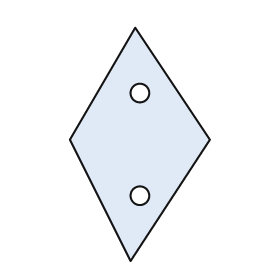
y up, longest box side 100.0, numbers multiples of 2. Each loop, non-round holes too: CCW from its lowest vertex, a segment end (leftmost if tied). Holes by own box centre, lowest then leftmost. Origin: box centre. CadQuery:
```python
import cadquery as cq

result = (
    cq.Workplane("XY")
    .moveTo(-4.0, -50.0)
    .lineTo(30.0, 2.0)
    .lineTo(-2.0, 50.0)
    .lineTo(-30.0, 2.0)
    .close()
    .moveTo(0.0, -22.0)
    .circle(4.0)
    .moveTo(0.0, 22.0)
    .circle(4.0)
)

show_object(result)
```